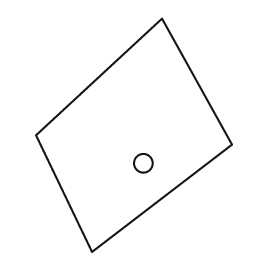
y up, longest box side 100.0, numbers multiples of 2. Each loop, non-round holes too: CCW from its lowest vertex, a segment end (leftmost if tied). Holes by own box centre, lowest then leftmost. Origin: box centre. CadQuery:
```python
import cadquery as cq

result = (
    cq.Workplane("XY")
    .moveTo(-18.0, -50.0)
    .lineTo(42.0, -4.0)
    .lineTo(12.0, 50.0)
    .lineTo(-42.0, 0.0)
    .close()
    .moveTo(4.0, -12.0)
    .circle(4.0)
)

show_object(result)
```